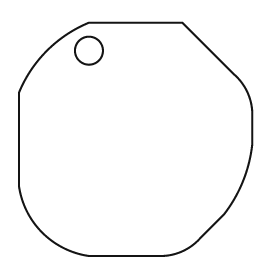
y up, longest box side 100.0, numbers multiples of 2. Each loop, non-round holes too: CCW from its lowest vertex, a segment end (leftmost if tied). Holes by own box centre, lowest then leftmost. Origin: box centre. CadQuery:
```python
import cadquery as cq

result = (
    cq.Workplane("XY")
    .moveTo(-20.0, -50.0)
    .lineTo(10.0, -50.0)
    .threePointArc((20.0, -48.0), (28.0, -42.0))
    .lineTo(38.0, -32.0)
    .threePointArc((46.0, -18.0), (50.0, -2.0))
    .lineTo(50.0, 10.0)
    .threePointArc((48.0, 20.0), (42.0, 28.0))
    .lineTo(20.0, 50.0)
    .lineTo(-20.0, 50.0)
    .threePointArc((-38.0, 38.0), (-50.0, 20.0))
    .lineTo(-50.0, -20.0)
    .threePointArc((-40.0, -40.0), (-20.0, -50.0))
    .close()
    .moveTo(-20.0, 38.0)
    .circle(6.0)
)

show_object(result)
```